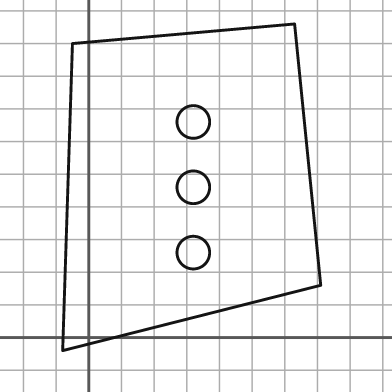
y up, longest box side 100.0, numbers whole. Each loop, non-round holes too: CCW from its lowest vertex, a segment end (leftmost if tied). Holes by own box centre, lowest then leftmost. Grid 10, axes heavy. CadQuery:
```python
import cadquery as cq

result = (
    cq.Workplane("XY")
    .moveTo(-8.0, -4.0)
    .lineTo(71.0, 16.0)
    .lineTo(63.0, 96.0)
    .lineTo(-5.0, 90.0)
    .close()
    .moveTo(32.0, 26.0)
    .circle(5.0)
    .moveTo(32.0, 46.0)
    .circle(5.0)
    .moveTo(32.0, 66.0)
    .circle(5.0)
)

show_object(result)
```